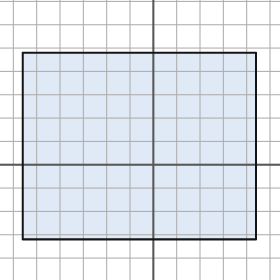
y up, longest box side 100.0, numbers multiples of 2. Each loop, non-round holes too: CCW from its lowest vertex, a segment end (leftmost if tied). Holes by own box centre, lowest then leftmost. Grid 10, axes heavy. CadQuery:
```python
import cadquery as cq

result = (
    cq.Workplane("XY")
    .moveTo(-56.0, -32.0)
    .lineTo(44.0, -32.0)
    .lineTo(44.0, 48.0)
    .lineTo(-56.0, 48.0)
    .close()
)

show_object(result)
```